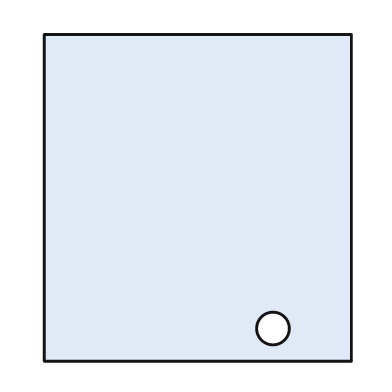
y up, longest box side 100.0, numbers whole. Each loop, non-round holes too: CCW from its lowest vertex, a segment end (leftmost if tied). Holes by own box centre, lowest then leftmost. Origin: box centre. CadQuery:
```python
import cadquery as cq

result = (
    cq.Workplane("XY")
    .moveTo(-47.0, -50.0)
    .lineTo(47.0, -50.0)
    .lineTo(47.0, 50.0)
    .lineTo(-47.0, 50.0)
    .close()
    .moveTo(23.0, -40.0)
    .circle(5.0)
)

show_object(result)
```